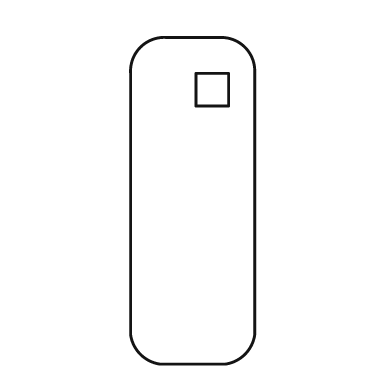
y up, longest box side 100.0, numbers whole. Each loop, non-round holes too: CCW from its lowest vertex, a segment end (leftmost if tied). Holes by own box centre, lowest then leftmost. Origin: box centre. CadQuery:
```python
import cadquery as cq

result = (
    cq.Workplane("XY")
    .moveTo(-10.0, -50.0)
    .lineTo(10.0, -50.0)
    .threePointArc((16.0, -47.0), (19.0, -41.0))
    .lineTo(19.0, 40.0)
    .threePointArc((16.0, 47.0), (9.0, 50.0))
    .lineTo(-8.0, 50.0)
    .threePointArc((-16.0, 47.0), (-19.0, 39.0))
    .lineTo(-19.0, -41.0)
    .threePointArc((-16.0, -47.0), (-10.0, -50.0))
    .close()
    .moveTo(1.0, 29.0)
    .lineTo(11.0, 29.0)
    .lineTo(11.0, 39.0)
    .lineTo(1.0, 39.0)
    .close()
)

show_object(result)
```